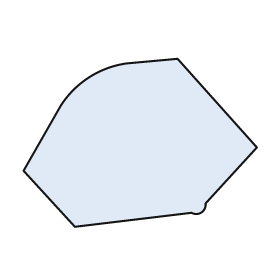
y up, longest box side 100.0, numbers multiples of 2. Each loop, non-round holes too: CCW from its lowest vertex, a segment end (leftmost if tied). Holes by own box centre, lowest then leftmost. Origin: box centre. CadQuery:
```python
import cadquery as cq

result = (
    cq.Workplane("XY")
    .moveTo(-28.0, -36.0)
    .lineTo(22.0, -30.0)
    .threePointArc((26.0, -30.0), (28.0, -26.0))
    .lineTo(50.0, -2.0)
    .lineTo(16.0, 36.0)
    .lineTo(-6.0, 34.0)
    .threePointArc((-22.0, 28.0), (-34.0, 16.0))
    .lineTo(-50.0, -12.0)
    .close()
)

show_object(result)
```